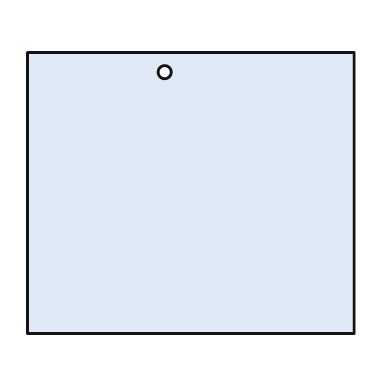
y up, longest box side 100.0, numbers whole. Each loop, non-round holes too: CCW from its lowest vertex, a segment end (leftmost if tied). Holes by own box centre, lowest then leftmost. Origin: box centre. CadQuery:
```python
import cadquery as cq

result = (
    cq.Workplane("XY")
    .moveTo(-50.0, -43.0)
    .lineTo(50.0, -43.0)
    .lineTo(50.0, 43.0)
    .lineTo(-50.0, 43.0)
    .close()
    .moveTo(-8.0, 37.0)
    .circle(2.0)
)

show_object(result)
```